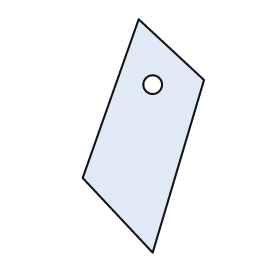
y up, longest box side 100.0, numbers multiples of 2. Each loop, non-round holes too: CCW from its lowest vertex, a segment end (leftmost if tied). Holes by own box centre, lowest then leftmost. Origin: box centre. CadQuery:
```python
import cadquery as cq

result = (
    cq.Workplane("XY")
    .moveTo(4.0, -50.0)
    .lineTo(26.0, 24.0)
    .lineTo(-2.0, 50.0)
    .lineTo(-26.0, -18.0)
    .close()
    .moveTo(4.0, 22.0)
    .circle(4.0)
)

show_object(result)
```